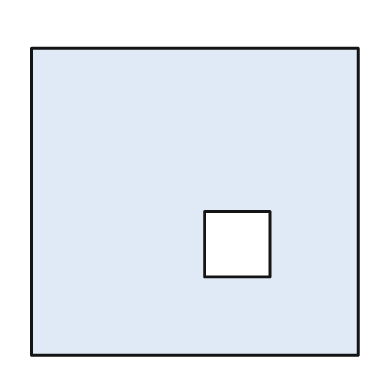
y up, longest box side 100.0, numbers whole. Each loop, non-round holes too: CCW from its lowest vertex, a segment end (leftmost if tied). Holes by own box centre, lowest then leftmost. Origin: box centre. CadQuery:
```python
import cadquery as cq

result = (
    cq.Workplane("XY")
    .moveTo(-50.0, -47.0)
    .lineTo(50.0, -47.0)
    .lineTo(50.0, 47.0)
    .lineTo(-50.0, 47.0)
    .close()
    .moveTo(3.0, -23.0)
    .lineTo(23.0, -23.0)
    .lineTo(23.0, -3.0)
    .lineTo(3.0, -3.0)
    .close()
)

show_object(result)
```